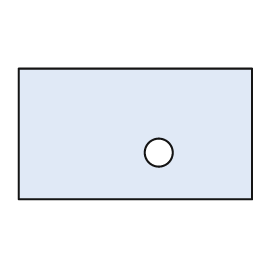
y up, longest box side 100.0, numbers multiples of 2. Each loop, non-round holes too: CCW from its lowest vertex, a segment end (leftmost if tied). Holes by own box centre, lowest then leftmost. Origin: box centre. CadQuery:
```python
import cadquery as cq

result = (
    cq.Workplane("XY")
    .moveTo(-50.0, -28.0)
    .lineTo(50.0, -28.0)
    .lineTo(50.0, 28.0)
    .lineTo(-50.0, 28.0)
    .close()
    .moveTo(10.0, -8.0)
    .circle(6.0)
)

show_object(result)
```